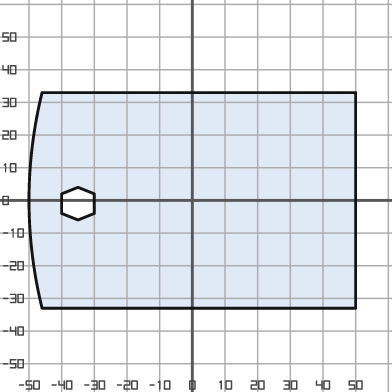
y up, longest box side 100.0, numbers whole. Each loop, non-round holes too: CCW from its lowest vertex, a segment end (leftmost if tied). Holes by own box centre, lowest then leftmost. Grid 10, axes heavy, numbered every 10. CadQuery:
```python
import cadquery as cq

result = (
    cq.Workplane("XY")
    .moveTo(-46.0, -33.0)
    .lineTo(50.0, -33.0)
    .lineTo(50.0, 33.0)
    .lineTo(-46.0, 33.0)
    .threePointArc((-50.0, 0.0), (-46.0, -33.0))
    .close()
    .moveTo(-35.0, -6.0)
    .lineTo(-30.0, -4.0)
    .lineTo(-30.0, 2.0)
    .lineTo(-35.0, 4.0)
    .lineTo(-40.0, 2.0)
    .lineTo(-40.0, -4.0)
    .close()
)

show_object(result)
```